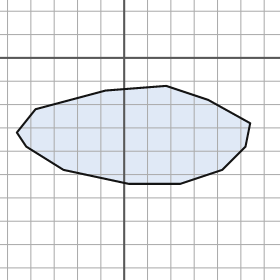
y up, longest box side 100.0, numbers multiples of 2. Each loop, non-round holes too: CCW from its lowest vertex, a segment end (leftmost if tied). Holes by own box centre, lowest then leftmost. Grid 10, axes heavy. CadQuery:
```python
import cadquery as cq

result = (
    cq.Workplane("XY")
    .moveTo(2.0, -54.0)
    .lineTo(24.0, -54.0)
    .lineTo(42.0, -48.0)
    .lineTo(52.0, -38.0)
    .lineTo(54.0, -28.0)
    .lineTo(36.0, -18.0)
    .lineTo(18.0, -12.0)
    .lineTo(-8.0, -14.0)
    .lineTo(-38.0, -22.0)
    .lineTo(-46.0, -32.0)
    .lineTo(-42.0, -38.0)
    .lineTo(-26.0, -48.0)
    .close()
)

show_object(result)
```